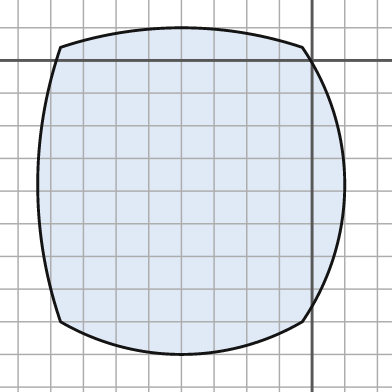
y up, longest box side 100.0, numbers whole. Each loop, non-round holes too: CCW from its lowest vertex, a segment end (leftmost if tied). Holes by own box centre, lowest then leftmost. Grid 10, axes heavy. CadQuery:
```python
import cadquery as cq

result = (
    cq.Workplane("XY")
    .moveTo(-77.0, -80.0)
    .threePointArc((-40.0, -90.0), (-3.0, -80.0))
    .threePointArc((10.0, -38.0), (-3.0, 4.0))
    .threePointArc((-40.0, 10.0), (-77.0, 4.0))
    .threePointArc((-84.0, -38.0), (-77.0, -80.0))
    .close()
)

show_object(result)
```